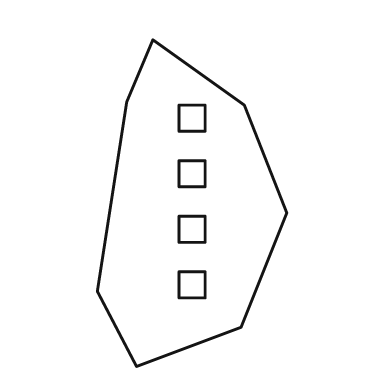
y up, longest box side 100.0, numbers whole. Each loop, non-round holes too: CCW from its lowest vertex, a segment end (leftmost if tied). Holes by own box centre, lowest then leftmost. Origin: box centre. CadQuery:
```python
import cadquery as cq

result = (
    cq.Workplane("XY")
    .moveTo(-17.0, -50.0)
    .lineTo(15.0, -38.0)
    .lineTo(29.0, -3.0)
    .lineTo(16.0, 30.0)
    .lineTo(-12.0, 50.0)
    .lineTo(-20.0, 31.0)
    .lineTo(-29.0, -27.0)
    .close()
    .moveTo(-4.0, -29.0)
    .lineTo(4.0, -29.0)
    .lineTo(4.0, -21.0)
    .lineTo(-4.0, -21.0)
    .close()
    .moveTo(-4.0, -12.0)
    .lineTo(4.0, -12.0)
    .lineTo(4.0, -4.0)
    .lineTo(-4.0, -4.0)
    .close()
    .moveTo(-4.0, 5.0)
    .lineTo(4.0, 5.0)
    .lineTo(4.0, 13.0)
    .lineTo(-4.0, 13.0)
    .close()
    .moveTo(-4.0, 22.0)
    .lineTo(4.0, 22.0)
    .lineTo(4.0, 30.0)
    .lineTo(-4.0, 30.0)
    .close()
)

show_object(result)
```